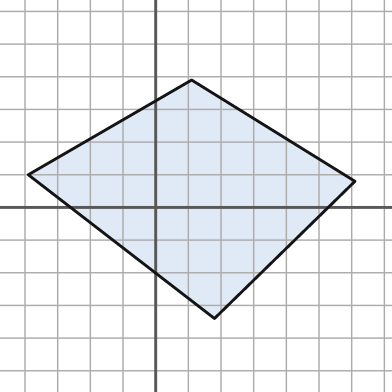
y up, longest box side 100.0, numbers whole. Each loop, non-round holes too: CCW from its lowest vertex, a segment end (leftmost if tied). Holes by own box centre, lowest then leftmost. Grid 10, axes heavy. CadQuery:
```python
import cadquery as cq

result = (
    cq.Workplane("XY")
    .moveTo(18.0, -34.0)
    .lineTo(61.0, 8.0)
    .lineTo(11.0, 39.0)
    .lineTo(-39.0, 10.0)
    .close()
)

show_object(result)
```